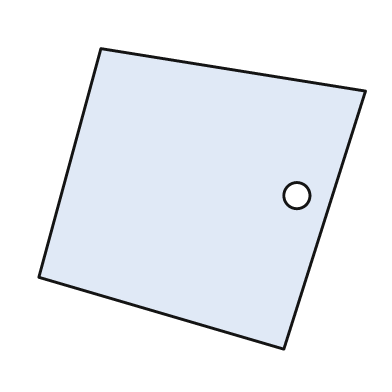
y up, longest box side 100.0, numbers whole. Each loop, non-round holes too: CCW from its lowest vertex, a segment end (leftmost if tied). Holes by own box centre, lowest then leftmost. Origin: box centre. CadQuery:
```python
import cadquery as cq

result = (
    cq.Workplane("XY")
    .moveTo(25.0, -46.0)
    .lineTo(50.0, 33.0)
    .lineTo(-31.0, 46.0)
    .lineTo(-50.0, -24.0)
    .close()
    .moveTo(29.0, 1.0)
    .circle(4.0)
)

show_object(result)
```